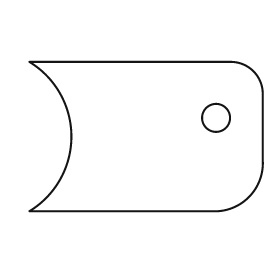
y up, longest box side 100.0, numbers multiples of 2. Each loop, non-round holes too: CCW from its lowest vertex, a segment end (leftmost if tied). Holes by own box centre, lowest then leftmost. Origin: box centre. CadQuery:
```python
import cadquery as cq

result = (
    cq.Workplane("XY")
    .moveTo(-50.0, -32.0)
    .lineTo(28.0, -32.0)
    .threePointArc((44.0, -26.0), (50.0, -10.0))
    .lineTo(50.0, 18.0)
    .threePointArc((46.0, 28.0), (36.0, 32.0))
    .lineTo(-50.0, 32.0)
    .threePointArc((-32.0, 0.0), (-50.0, -32.0))
    .close()
    .moveTo(30.0, 8.0)
    .circle(6.0)
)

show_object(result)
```